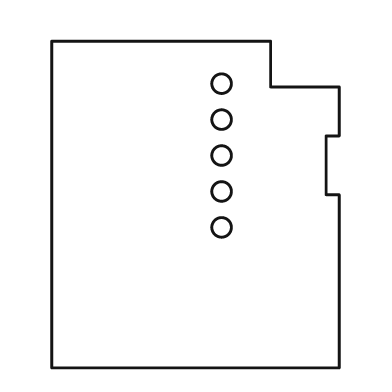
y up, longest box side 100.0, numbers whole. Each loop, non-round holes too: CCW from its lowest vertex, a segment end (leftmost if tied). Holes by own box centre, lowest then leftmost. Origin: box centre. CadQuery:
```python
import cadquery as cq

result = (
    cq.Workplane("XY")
    .moveTo(-44.0, -50.0)
    .lineTo(44.0, -50.0)
    .lineTo(44.0, 3.0)
    .lineTo(40.0, 3.0)
    .lineTo(40.0, 21.0)
    .lineTo(44.0, 21.0)
    .lineTo(44.0, 36.0)
    .lineTo(23.0, 36.0)
    .lineTo(23.0, 50.0)
    .lineTo(-44.0, 50.0)
    .close()
    .moveTo(8.0, -7.0)
    .circle(3.0)
    .moveTo(8.0, 4.0)
    .circle(3.0)
    .moveTo(8.0, 15.0)
    .circle(3.0)
    .moveTo(8.0, 26.0)
    .circle(3.0)
    .moveTo(8.0, 37.0)
    .circle(3.0)
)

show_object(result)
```